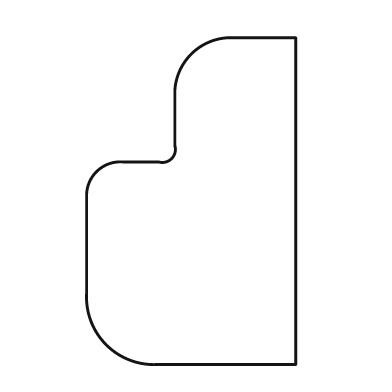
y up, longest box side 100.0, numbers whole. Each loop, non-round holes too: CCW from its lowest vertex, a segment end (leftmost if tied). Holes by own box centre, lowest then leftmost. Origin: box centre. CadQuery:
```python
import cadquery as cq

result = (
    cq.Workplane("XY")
    .moveTo(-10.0, -50.0)
    .lineTo(32.0, -50.0)
    .lineTo(32.0, 50.0)
    .lineTo(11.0, 50.0)
    .threePointArc((0.0, 45.0), (-5.0, 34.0))
    .lineTo(-5.0, 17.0)
    .threePointArc((-6.0, 13.0), (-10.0, 12.0))
    .lineTo(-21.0, 12.0)
    .threePointArc((-29.0, 9.0), (-32.0, 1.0))
    .lineTo(-32.0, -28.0)
    .threePointArc((-26.0, -44.0), (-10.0, -50.0))
    .close()
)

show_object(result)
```